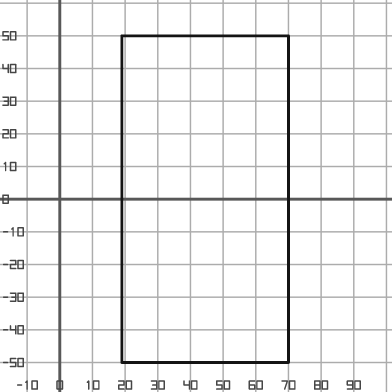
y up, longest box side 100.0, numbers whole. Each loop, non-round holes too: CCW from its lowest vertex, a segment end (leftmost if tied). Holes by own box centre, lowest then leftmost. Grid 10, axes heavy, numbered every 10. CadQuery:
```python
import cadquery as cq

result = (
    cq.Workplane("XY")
    .moveTo(19.0, -50.0)
    .lineTo(70.0, -50.0)
    .lineTo(70.0, 50.0)
    .lineTo(19.0, 50.0)
    .close()
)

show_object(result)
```